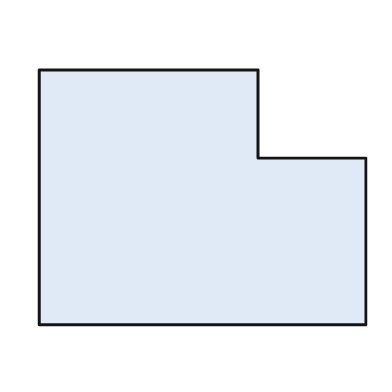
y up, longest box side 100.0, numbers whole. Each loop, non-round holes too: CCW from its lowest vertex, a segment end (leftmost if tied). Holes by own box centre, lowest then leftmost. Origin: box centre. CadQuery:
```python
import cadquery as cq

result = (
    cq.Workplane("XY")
    .moveTo(-50.0, -39.0)
    .lineTo(50.0, -39.0)
    .lineTo(50.0, 12.0)
    .lineTo(17.0, 12.0)
    .lineTo(17.0, 39.0)
    .lineTo(-50.0, 39.0)
    .close()
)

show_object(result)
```